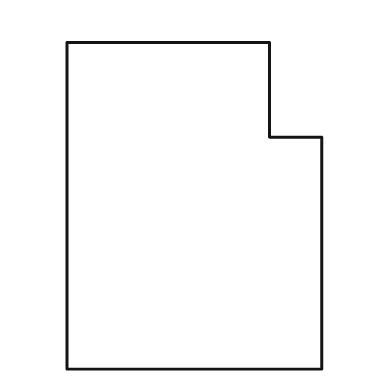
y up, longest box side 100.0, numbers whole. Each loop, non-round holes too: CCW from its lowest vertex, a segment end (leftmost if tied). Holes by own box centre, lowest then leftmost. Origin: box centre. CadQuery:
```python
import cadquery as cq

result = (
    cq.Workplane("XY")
    .moveTo(-39.0, -50.0)
    .lineTo(39.0, -50.0)
    .lineTo(39.0, 21.0)
    .lineTo(23.0, 21.0)
    .lineTo(23.0, 50.0)
    .lineTo(-39.0, 50.0)
    .close()
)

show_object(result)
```